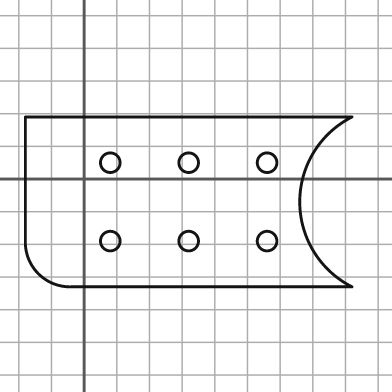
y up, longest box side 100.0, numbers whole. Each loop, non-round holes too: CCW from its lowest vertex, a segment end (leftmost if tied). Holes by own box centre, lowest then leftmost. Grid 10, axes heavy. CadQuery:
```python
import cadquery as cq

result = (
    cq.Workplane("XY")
    .moveTo(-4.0, -33.0)
    .lineTo(82.0, -33.0)
    .threePointArc((66.0, -7.0), (82.0, 19.0))
    .lineTo(-18.0, 19.0)
    .lineTo(-18.0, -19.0)
    .threePointArc((-14.0, -29.0), (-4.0, -33.0))
    .close()
    .moveTo(8.0, -19.0)
    .circle(3.0)
    .moveTo(32.0, -19.0)
    .circle(3.0)
    .moveTo(56.0, -19.0)
    .circle(3.0)
    .moveTo(8.0, 5.0)
    .circle(3.0)
    .moveTo(32.0, 5.0)
    .circle(3.0)
    .moveTo(56.0, 5.0)
    .circle(3.0)
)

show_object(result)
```